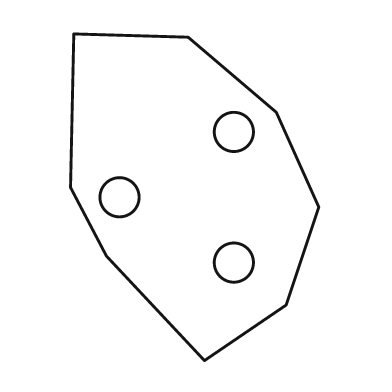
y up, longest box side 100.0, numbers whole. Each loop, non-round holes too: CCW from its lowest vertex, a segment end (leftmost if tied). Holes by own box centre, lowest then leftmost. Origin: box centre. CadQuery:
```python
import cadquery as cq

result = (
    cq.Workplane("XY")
    .moveTo(3.0, -50.0)
    .lineTo(28.0, -33.0)
    .lineTo(38.0, -3.0)
    .lineTo(25.0, 26.0)
    .lineTo(-2.0, 49.0)
    .lineTo(-37.0, 50.0)
    .lineTo(-38.0, 3.0)
    .lineTo(-27.0, -18.0)
    .close()
    .moveTo(12.0, -20.0)
    .circle(6.0)
    .moveTo(-23.0, 0.0)
    .circle(6.0)
    .moveTo(12.0, 20.0)
    .circle(6.0)
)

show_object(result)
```